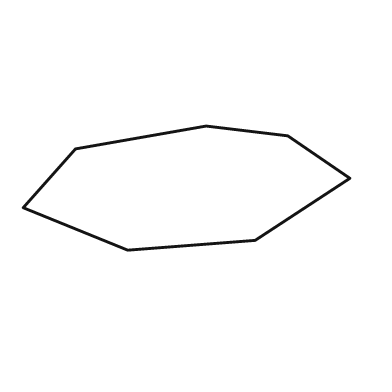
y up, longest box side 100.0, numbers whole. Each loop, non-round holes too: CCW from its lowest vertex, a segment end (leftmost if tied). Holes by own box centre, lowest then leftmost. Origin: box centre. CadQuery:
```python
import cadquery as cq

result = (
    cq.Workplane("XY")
    .moveTo(-18.0, -19.0)
    .lineTo(21.0, -16.0)
    .lineTo(50.0, 3.0)
    .lineTo(31.0, 16.0)
    .lineTo(6.0, 19.0)
    .lineTo(-34.0, 12.0)
    .lineTo(-50.0, -6.0)
    .close()
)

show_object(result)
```